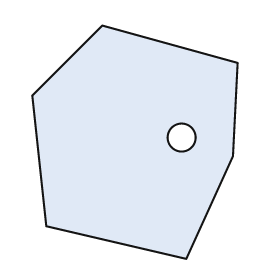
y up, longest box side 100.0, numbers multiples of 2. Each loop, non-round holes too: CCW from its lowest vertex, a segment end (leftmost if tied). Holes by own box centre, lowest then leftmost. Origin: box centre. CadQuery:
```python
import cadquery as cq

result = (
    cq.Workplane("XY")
    .moveTo(22.0, -50.0)
    .lineTo(42.0, -6.0)
    .lineTo(44.0, 34.0)
    .lineTo(-14.0, 50.0)
    .lineTo(-44.0, 20.0)
    .lineTo(-38.0, -36.0)
    .close()
    .moveTo(20.0, 2.0)
    .circle(6.0)
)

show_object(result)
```